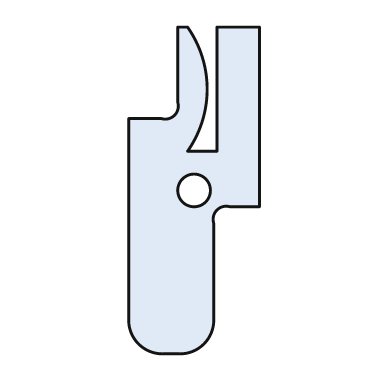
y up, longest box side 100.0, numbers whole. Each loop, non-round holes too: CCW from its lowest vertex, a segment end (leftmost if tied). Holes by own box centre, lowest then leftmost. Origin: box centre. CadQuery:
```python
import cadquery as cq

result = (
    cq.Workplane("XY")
    .moveTo(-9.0, -50.0)
    .lineTo(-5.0, -50.0)
    .threePointArc((3.0, -47.0), (6.0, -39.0))
    .lineTo(6.0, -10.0)
    .threePointArc((7.0, -6.0), (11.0, -5.0))
    .lineTo(20.0, -5.0)
    .lineTo(20.0, 50.0)
    .lineTo(7.0, 50.0)
    .lineTo(7.0, 12.0)
    .lineTo(-2.0, 12.0)
    .threePointArc((4.0, 31.0), (-2.0, 50.0))
    .lineTo(-5.0, 50.0)
    .lineTo(-5.0, 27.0)
    .threePointArc((-6.0, 23.0), (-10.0, 22.0))
    .lineTo(-20.0, 22.0)
    .lineTo(-20.0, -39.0)
    .threePointArc((-17.0, -47.0), (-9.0, -50.0))
    .close()
    .moveTo(0.0, 0.0)
    .circle(5.0)
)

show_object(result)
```